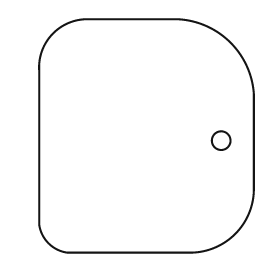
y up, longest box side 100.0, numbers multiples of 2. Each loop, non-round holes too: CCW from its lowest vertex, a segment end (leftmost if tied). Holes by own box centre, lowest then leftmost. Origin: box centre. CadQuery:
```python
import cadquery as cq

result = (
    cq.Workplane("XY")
    .moveTo(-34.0, -50.0)
    .lineTo(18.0, -50.0)
    .threePointArc((38.0, -42.0), (46.0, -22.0))
    .lineTo(46.0, 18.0)
    .threePointArc((36.0, 40.0), (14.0, 50.0))
    .lineTo(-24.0, 50.0)
    .threePointArc((-40.0, 44.0), (-46.0, 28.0))
    .lineTo(-46.0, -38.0)
    .threePointArc((-42.0, -46.0), (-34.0, -50.0))
    .close()
    .moveTo(32.0, -2.0)
    .circle(4.0)
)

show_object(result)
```